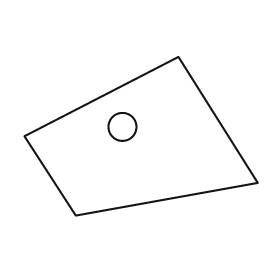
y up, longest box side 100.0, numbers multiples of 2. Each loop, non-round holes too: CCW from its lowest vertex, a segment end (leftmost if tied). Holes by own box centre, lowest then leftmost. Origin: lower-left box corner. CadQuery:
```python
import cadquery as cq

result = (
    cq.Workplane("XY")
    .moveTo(22.0, 0.0)
    .lineTo(100.0, 14.0)
    .lineTo(66.0, 68.0)
    .lineTo(0.0, 34.0)
    .close()
    .moveTo(42.0, 38.0)
    .circle(6.0)
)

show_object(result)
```